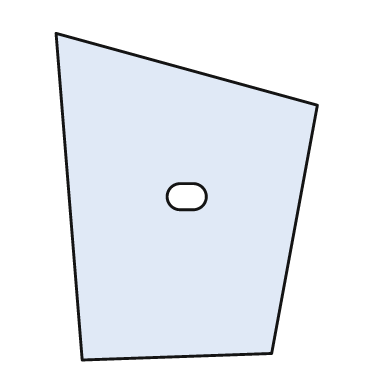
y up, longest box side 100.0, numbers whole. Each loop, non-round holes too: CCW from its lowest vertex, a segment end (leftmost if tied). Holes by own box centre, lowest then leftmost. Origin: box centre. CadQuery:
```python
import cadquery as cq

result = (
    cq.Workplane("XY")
    .moveTo(-32.0, -50.0)
    .lineTo(26.0, -48.0)
    .lineTo(40.0, 28.0)
    .lineTo(-40.0, 50.0)
    .close()
    .moveTo(-2.0, -4.0)
    .lineTo(2.0, -4.0)
    .threePointArc((6.0, 0.0), (2.0, 4.0))
    .lineTo(-2.0, 4.0)
    .threePointArc((-6.0, 0.0), (-2.0, -4.0))
    .close()
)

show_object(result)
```